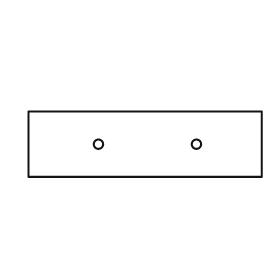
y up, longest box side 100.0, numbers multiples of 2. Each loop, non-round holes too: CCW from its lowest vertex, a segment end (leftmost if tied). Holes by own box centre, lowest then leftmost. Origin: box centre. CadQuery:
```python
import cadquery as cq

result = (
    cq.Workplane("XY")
    .moveTo(-50.0, -14.0)
    .lineTo(50.0, -14.0)
    .lineTo(50.0, 14.0)
    .lineTo(-50.0, 14.0)
    .close()
    .moveTo(-20.0, 0.0)
    .circle(2.0)
    .moveTo(22.0, 0.0)
    .circle(2.0)
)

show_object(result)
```